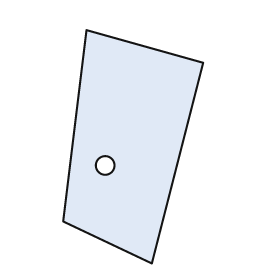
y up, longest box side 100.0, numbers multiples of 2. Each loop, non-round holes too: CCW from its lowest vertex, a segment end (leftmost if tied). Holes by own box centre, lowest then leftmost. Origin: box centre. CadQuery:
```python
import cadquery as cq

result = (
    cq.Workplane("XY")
    .moveTo(8.0, -50.0)
    .lineTo(30.0, 36.0)
    .lineTo(-20.0, 50.0)
    .lineTo(-30.0, -32.0)
    .close()
    .moveTo(-12.0, -8.0)
    .circle(4.0)
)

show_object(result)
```